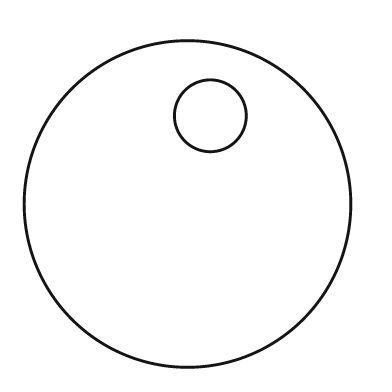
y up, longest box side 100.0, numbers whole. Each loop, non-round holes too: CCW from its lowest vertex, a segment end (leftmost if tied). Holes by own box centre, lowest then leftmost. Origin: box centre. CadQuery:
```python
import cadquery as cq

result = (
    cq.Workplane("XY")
    .moveTo(0.0, 0.0)
    .circle(50.0)
    .moveTo(7.0, 27.0)
    .circle(11.0)
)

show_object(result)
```